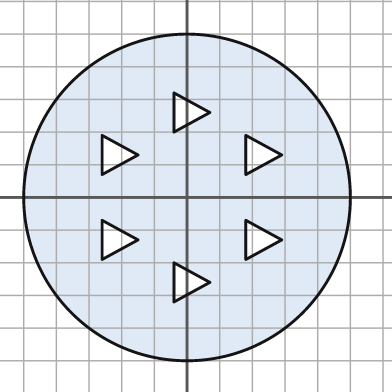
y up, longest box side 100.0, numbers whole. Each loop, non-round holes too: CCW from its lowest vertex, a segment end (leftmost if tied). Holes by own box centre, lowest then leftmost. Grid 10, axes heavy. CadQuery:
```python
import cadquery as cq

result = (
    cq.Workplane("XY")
    .moveTo(0.0, 0.0)
    .circle(50.0)
    .moveTo(-4.0, -32.0)
    .lineTo(7.0, -26.0)
    .lineTo(-4.0, -20.0)
    .close()
    .moveTo(-26.0, -19.0)
    .lineTo(-15.0, -13.0)
    .lineTo(-26.0, -7.0)
    .close()
    .moveTo(18.0, -19.0)
    .lineTo(29.0, -13.0)
    .lineTo(18.0, -7.0)
    .close()
    .moveTo(-26.0, 7.0)
    .lineTo(-15.0, 13.0)
    .lineTo(-26.0, 19.0)
    .close()
    .moveTo(18.0, 7.0)
    .lineTo(29.0, 13.0)
    .lineTo(18.0, 19.0)
    .close()
    .moveTo(-4.0, 20.0)
    .lineTo(7.0, 26.0)
    .lineTo(-4.0, 32.0)
    .close()
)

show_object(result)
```